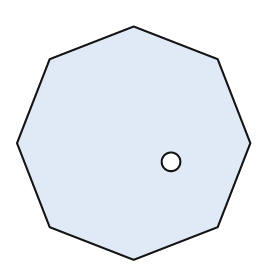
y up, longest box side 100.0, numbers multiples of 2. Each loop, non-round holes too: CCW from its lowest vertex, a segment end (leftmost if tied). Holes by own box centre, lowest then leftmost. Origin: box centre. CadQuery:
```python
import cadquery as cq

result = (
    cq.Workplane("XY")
    .moveTo(0.0, -50.0)
    .lineTo(36.0, -36.0)
    .lineTo(50.0, 0.0)
    .lineTo(36.0, 36.0)
    .lineTo(0.0, 50.0)
    .lineTo(-36.0, 36.0)
    .lineTo(-50.0, 0.0)
    .lineTo(-36.0, -36.0)
    .close()
    .moveTo(16.0, -8.0)
    .circle(4.0)
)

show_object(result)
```